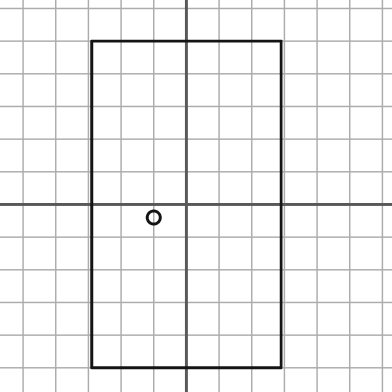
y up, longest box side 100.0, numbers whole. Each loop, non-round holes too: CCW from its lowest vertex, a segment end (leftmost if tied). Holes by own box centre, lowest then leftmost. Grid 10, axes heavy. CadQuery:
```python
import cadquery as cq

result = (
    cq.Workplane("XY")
    .moveTo(-29.0, -50.0)
    .lineTo(29.0, -50.0)
    .lineTo(29.0, 50.0)
    .lineTo(-29.0, 50.0)
    .close()
    .moveTo(-10.0, -4.0)
    .circle(2.0)
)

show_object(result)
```